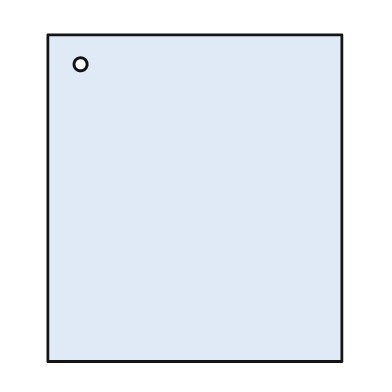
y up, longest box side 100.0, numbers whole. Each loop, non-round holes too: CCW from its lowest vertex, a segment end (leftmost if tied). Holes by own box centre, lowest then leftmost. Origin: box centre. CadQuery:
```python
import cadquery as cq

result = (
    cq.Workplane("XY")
    .moveTo(-45.0, -50.0)
    .lineTo(45.0, -50.0)
    .lineTo(45.0, 50.0)
    .lineTo(-45.0, 50.0)
    .close()
    .moveTo(-35.0, 41.0)
    .circle(2.0)
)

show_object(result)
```